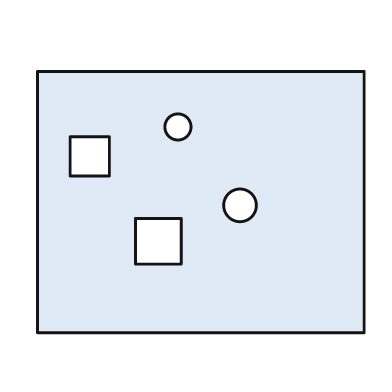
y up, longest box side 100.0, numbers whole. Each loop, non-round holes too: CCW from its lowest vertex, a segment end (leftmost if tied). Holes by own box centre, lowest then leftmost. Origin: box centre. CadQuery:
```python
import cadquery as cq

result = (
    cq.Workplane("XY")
    .moveTo(-50.0, -40.0)
    .lineTo(50.0, -40.0)
    .lineTo(50.0, 40.0)
    .lineTo(-50.0, 40.0)
    .close()
    .moveTo(-20.0, -19.0)
    .lineTo(-6.0, -19.0)
    .lineTo(-6.0, -5.0)
    .lineTo(-20.0, -5.0)
    .close()
    .moveTo(12.0, -1.0)
    .circle(5.0)
    .moveTo(-40.0, 8.0)
    .lineTo(-28.0, 8.0)
    .lineTo(-28.0, 20.0)
    .lineTo(-40.0, 20.0)
    .close()
    .moveTo(-7.0, 23.0)
    .circle(4.0)
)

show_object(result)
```